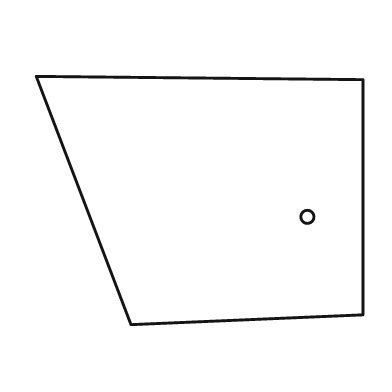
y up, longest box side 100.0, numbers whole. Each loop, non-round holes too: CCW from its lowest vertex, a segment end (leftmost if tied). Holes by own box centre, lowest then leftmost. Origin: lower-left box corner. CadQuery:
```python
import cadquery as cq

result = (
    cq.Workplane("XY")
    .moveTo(29.0, 0.0)
    .lineTo(100.0, 3.0)
    .lineTo(100.0, 75.0)
    .lineTo(0.0, 76.0)
    .close()
    .moveTo(83.0, 33.0)
    .circle(2.0)
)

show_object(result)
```